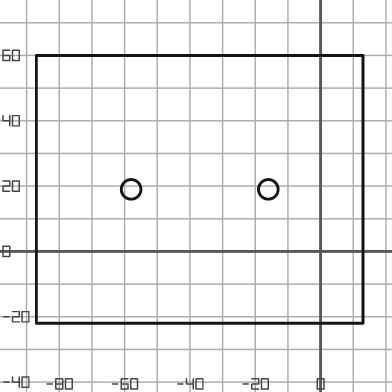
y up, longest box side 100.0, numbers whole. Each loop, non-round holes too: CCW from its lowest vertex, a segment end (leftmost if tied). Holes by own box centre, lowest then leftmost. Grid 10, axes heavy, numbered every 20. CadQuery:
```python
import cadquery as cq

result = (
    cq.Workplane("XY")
    .moveTo(-87.0, -22.0)
    .lineTo(13.0, -22.0)
    .lineTo(13.0, 60.0)
    .lineTo(-87.0, 60.0)
    .close()
    .moveTo(-58.0, 19.0)
    .circle(3.0)
    .moveTo(-16.0, 19.0)
    .circle(3.0)
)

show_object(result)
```